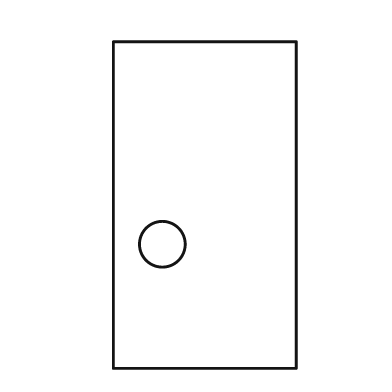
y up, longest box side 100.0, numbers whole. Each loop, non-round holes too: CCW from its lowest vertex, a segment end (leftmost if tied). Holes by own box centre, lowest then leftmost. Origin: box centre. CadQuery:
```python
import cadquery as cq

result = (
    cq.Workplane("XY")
    .moveTo(-28.0, -50.0)
    .lineTo(28.0, -50.0)
    .lineTo(28.0, 50.0)
    .lineTo(-28.0, 50.0)
    .close()
    .moveTo(-13.0, -12.0)
    .circle(7.0)
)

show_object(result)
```